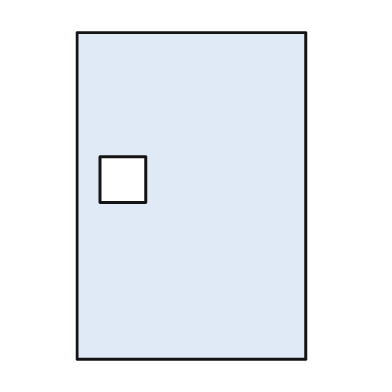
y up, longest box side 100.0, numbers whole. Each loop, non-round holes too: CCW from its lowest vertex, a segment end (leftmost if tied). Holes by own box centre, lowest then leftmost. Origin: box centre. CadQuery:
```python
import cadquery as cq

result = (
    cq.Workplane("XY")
    .moveTo(-35.0, -50.0)
    .lineTo(35.0, -50.0)
    .lineTo(35.0, 50.0)
    .lineTo(-35.0, 50.0)
    .close()
    .moveTo(-28.0, -2.0)
    .lineTo(-14.0, -2.0)
    .lineTo(-14.0, 12.0)
    .lineTo(-28.0, 12.0)
    .close()
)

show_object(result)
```